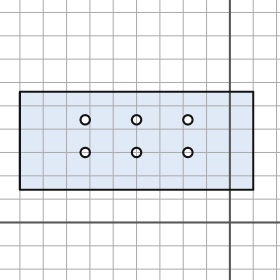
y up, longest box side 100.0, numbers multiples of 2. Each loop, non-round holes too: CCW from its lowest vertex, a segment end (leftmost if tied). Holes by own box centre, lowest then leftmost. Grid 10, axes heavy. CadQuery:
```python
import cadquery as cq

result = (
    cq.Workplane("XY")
    .moveTo(-90.0, 14.0)
    .lineTo(10.0, 14.0)
    .lineTo(10.0, 56.0)
    .lineTo(-90.0, 56.0)
    .close()
    .moveTo(-62.0, 30.0)
    .circle(2.0)
    .moveTo(-40.0, 30.0)
    .circle(2.0)
    .moveTo(-18.0, 30.0)
    .circle(2.0)
    .moveTo(-62.0, 44.0)
    .circle(2.0)
    .moveTo(-40.0, 44.0)
    .circle(2.0)
    .moveTo(-18.0, 44.0)
    .circle(2.0)
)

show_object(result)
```